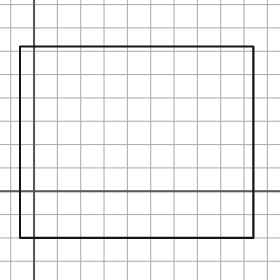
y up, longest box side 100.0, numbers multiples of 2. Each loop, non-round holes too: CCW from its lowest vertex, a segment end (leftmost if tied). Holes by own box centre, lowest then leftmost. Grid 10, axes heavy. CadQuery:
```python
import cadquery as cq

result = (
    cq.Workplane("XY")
    .moveTo(-6.0, -20.0)
    .lineTo(94.0, -20.0)
    .lineTo(94.0, 62.0)
    .lineTo(-6.0, 62.0)
    .close()
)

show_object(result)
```